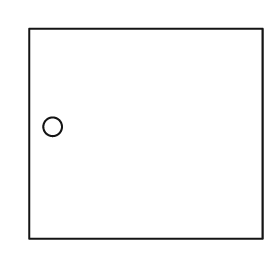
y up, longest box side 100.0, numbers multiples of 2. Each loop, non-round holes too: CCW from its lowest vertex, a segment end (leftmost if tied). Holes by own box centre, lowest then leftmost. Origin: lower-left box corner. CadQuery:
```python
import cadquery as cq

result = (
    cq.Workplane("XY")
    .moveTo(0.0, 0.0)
    .lineTo(100.0, 0.0)
    .lineTo(100.0, 90.0)
    .lineTo(0.0, 90.0)
    .close()
    .moveTo(10.0, 48.0)
    .circle(4.0)
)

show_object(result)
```